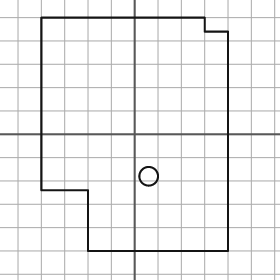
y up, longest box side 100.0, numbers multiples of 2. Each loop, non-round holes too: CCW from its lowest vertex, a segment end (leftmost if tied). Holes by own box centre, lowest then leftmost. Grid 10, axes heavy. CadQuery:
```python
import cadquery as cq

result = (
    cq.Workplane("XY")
    .moveTo(-20.0, -50.0)
    .lineTo(40.0, -50.0)
    .lineTo(40.0, 44.0)
    .lineTo(30.0, 44.0)
    .lineTo(30.0, 50.0)
    .lineTo(-40.0, 50.0)
    .lineTo(-40.0, -24.0)
    .lineTo(-20.0, -24.0)
    .close()
    .moveTo(6.0, -18.0)
    .circle(4.0)
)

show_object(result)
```